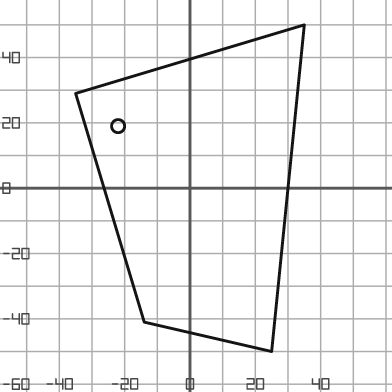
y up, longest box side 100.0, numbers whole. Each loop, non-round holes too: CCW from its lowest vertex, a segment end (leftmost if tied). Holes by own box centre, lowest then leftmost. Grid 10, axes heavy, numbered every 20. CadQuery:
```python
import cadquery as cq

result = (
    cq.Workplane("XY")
    .moveTo(25.0, -50.0)
    .lineTo(35.0, 50.0)
    .lineTo(-35.0, 29.0)
    .lineTo(-14.0, -41.0)
    .close()
    .moveTo(-22.0, 19.0)
    .circle(2.0)
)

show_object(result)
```